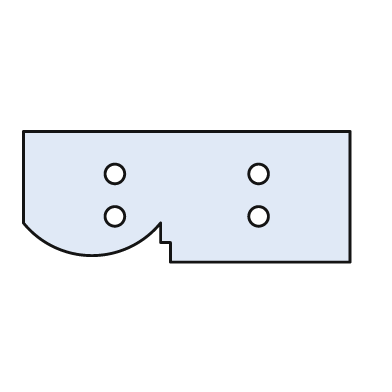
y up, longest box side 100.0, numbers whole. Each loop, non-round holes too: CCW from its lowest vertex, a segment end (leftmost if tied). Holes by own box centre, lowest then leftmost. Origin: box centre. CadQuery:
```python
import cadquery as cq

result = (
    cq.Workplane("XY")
    .moveTo(-5.0, -20.0)
    .lineTo(50.0, -20.0)
    .lineTo(50.0, 20.0)
    .lineTo(-50.0, 20.0)
    .lineTo(-50.0, -8.0)
    .threePointArc((-29.0, -18.0), (-8.0, -8.0))
    .lineTo(-8.0, -14.0)
    .lineTo(-5.0, -14.0)
    .close()
    .moveTo(-22.0, -6.0)
    .circle(3.0)
    .moveTo(22.0, -6.0)
    .circle(3.0)
    .moveTo(-22.0, 7.0)
    .circle(3.0)
    .moveTo(22.0, 7.0)
    .circle(3.0)
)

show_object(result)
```